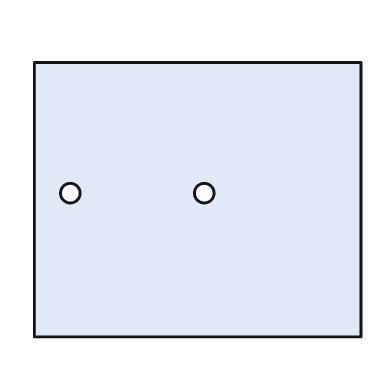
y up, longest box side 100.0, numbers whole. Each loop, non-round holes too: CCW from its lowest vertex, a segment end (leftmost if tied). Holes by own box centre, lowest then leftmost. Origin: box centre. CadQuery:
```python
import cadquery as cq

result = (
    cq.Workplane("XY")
    .moveTo(-50.0, -42.0)
    .lineTo(50.0, -42.0)
    .lineTo(50.0, 42.0)
    .lineTo(-50.0, 42.0)
    .close()
    .moveTo(-39.0, 2.0)
    .circle(3.0)
    .moveTo(2.0, 2.0)
    .circle(3.0)
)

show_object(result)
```